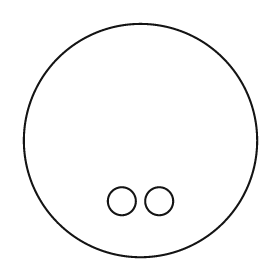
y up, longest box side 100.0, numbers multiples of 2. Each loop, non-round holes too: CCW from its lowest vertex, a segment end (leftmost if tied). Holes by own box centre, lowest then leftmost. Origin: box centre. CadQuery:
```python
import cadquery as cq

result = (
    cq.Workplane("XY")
    .moveTo(0.0, 0.0)
    .circle(50.0)
    .moveTo(-8.0, -26.0)
    .circle(6.0)
    .moveTo(8.0, -26.0)
    .circle(6.0)
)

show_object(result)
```